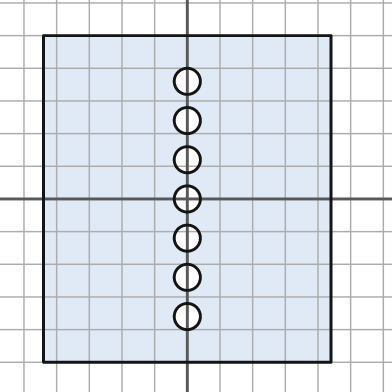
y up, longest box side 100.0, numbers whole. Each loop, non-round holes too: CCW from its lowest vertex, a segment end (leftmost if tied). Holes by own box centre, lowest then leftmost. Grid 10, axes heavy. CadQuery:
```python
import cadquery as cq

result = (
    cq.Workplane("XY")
    .moveTo(-44.0, -50.0)
    .lineTo(44.0, -50.0)
    .lineTo(44.0, 50.0)
    .lineTo(-44.0, 50.0)
    .close()
    .moveTo(0.0, -36.0)
    .circle(4.0)
    .moveTo(0.0, -24.0)
    .circle(4.0)
    .moveTo(0.0, -12.0)
    .circle(4.0)
    .moveTo(0.0, 0.0)
    .circle(4.0)
    .moveTo(0.0, 12.0)
    .circle(4.0)
    .moveTo(0.0, 24.0)
    .circle(4.0)
    .moveTo(0.0, 36.0)
    .circle(4.0)
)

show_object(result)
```